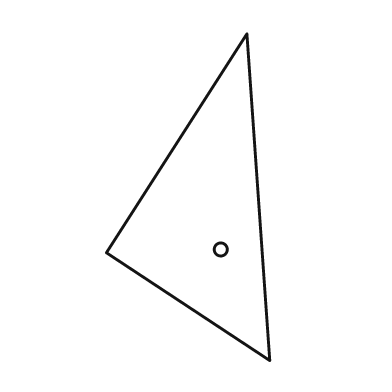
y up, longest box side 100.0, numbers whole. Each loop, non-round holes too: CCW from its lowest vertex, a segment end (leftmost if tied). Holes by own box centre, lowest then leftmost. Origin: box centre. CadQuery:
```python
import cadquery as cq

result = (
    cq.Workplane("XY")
    .moveTo(25.0, -50.0)
    .lineTo(18.0, 50.0)
    .lineTo(-25.0, -17.0)
    .close()
    .moveTo(10.0, -16.0)
    .circle(2.0)
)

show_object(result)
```